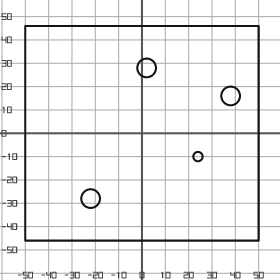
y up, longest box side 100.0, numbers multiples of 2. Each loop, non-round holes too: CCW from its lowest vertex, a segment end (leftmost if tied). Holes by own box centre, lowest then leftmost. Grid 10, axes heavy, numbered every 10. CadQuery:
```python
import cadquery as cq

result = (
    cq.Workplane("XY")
    .moveTo(-50.0, -46.0)
    .lineTo(50.0, -46.0)
    .lineTo(50.0, 46.0)
    .lineTo(-50.0, 46.0)
    .close()
    .moveTo(-22.0, -28.0)
    .circle(4.0)
    .moveTo(24.0, -10.0)
    .circle(2.0)
    .moveTo(38.0, 16.0)
    .circle(4.0)
    .moveTo(2.0, 28.0)
    .circle(4.0)
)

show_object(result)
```